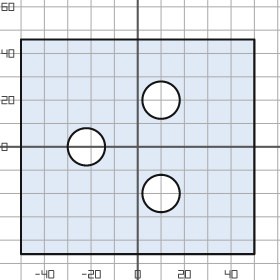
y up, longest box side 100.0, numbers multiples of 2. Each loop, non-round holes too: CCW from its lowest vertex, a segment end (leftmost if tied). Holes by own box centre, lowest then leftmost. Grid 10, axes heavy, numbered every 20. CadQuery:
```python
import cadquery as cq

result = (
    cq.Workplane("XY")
    .moveTo(-50.0, -46.0)
    .lineTo(50.0, -46.0)
    .lineTo(50.0, 46.0)
    .lineTo(-50.0, 46.0)
    .close()
    .moveTo(10.0, -20.0)
    .circle(8.0)
    .moveTo(-22.0, 0.0)
    .circle(8.0)
    .moveTo(10.0, 20.0)
    .circle(8.0)
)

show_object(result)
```